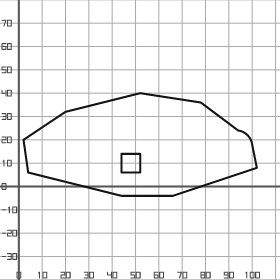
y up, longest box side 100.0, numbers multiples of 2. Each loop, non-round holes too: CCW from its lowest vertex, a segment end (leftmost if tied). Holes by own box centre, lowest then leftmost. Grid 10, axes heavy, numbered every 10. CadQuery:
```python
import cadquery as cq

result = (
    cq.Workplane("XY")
    .moveTo(44.0, -4.0)
    .lineTo(66.0, -4.0)
    .lineTo(102.0, 8.0)
    .lineTo(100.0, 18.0)
    .threePointArc((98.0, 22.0), (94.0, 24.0))
    .lineTo(78.0, 36.0)
    .lineTo(52.0, 40.0)
    .lineTo(20.0, 32.0)
    .lineTo(2.0, 20.0)
    .lineTo(4.0, 6.0)
    .close()
    .moveTo(44.0, 6.0)
    .lineTo(52.0, 6.0)
    .lineTo(52.0, 14.0)
    .lineTo(44.0, 14.0)
    .close()
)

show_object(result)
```